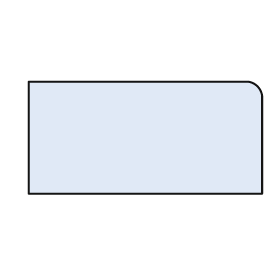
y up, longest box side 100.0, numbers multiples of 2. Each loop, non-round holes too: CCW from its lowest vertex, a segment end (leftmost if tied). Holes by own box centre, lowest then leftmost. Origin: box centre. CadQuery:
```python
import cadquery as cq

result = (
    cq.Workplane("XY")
    .moveTo(-50.0, -24.0)
    .lineTo(50.0, -24.0)
    .lineTo(50.0, 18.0)
    .threePointArc((48.0, 22.0), (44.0, 24.0))
    .lineTo(-50.0, 24.0)
    .close()
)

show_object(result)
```